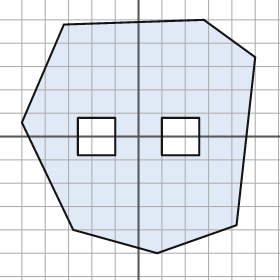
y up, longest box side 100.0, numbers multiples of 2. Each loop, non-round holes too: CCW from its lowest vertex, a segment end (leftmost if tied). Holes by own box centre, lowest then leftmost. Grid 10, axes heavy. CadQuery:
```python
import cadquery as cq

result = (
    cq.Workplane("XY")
    .moveTo(8.0, -50.0)
    .lineTo(42.0, -38.0)
    .lineTo(50.0, 34.0)
    .lineTo(28.0, 50.0)
    .lineTo(-32.0, 48.0)
    .lineTo(-50.0, 6.0)
    .lineTo(-28.0, -40.0)
    .close()
    .moveTo(-26.0, -8.0)
    .lineTo(-10.0, -8.0)
    .lineTo(-10.0, 8.0)
    .lineTo(-26.0, 8.0)
    .close()
    .moveTo(10.0, -8.0)
    .lineTo(26.0, -8.0)
    .lineTo(26.0, 8.0)
    .lineTo(10.0, 8.0)
    .close()
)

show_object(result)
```